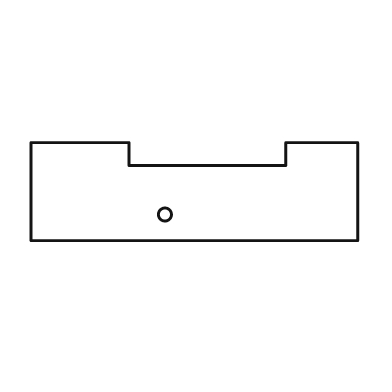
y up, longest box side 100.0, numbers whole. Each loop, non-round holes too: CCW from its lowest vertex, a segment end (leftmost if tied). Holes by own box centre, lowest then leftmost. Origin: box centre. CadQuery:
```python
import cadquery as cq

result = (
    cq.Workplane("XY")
    .moveTo(-50.0, -15.0)
    .lineTo(50.0, -15.0)
    .lineTo(50.0, 15.0)
    .lineTo(28.0, 15.0)
    .lineTo(28.0, 8.0)
    .lineTo(-20.0, 8.0)
    .lineTo(-20.0, 15.0)
    .lineTo(-50.0, 15.0)
    .close()
    .moveTo(-9.0, -7.0)
    .circle(2.0)
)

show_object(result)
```